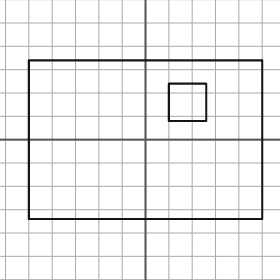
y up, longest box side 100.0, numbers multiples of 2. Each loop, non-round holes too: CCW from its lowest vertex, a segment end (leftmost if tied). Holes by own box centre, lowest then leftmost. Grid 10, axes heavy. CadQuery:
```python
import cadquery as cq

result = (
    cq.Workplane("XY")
    .moveTo(-50.0, -34.0)
    .lineTo(50.0, -34.0)
    .lineTo(50.0, 34.0)
    .lineTo(-50.0, 34.0)
    .close()
    .moveTo(10.0, 8.0)
    .lineTo(26.0, 8.0)
    .lineTo(26.0, 24.0)
    .lineTo(10.0, 24.0)
    .close()
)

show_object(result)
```